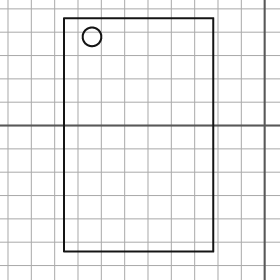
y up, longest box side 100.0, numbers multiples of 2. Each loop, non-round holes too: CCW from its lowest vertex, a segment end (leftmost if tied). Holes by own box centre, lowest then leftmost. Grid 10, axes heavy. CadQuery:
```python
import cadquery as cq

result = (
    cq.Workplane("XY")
    .moveTo(-86.0, -54.0)
    .lineTo(-22.0, -54.0)
    .lineTo(-22.0, 46.0)
    .lineTo(-86.0, 46.0)
    .close()
    .moveTo(-74.0, 38.0)
    .circle(4.0)
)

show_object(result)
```